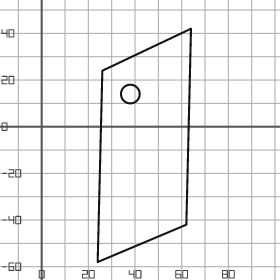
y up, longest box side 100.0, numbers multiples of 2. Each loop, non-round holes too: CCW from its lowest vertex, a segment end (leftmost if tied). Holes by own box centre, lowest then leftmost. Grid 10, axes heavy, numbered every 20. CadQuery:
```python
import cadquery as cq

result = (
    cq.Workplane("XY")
    .moveTo(24.0, -58.0)
    .lineTo(62.0, -42.0)
    .lineTo(64.0, 42.0)
    .lineTo(26.0, 24.0)
    .close()
    .moveTo(38.0, 14.0)
    .circle(4.0)
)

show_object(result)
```